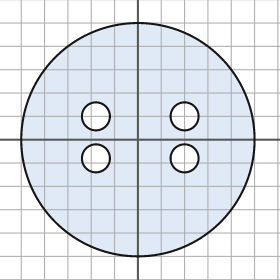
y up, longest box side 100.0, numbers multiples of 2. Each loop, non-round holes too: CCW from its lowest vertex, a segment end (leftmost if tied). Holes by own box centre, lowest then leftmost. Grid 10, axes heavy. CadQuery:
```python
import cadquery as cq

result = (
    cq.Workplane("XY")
    .moveTo(0.0, 0.0)
    .circle(50.0)
    .moveTo(-18.0, -8.0)
    .circle(6.0)
    .moveTo(20.0, -8.0)
    .circle(6.0)
    .moveTo(-18.0, 10.0)
    .circle(6.0)
    .moveTo(20.0, 10.0)
    .circle(6.0)
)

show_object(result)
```